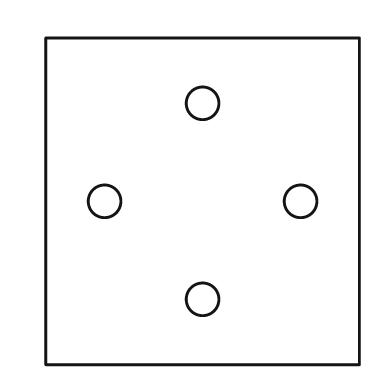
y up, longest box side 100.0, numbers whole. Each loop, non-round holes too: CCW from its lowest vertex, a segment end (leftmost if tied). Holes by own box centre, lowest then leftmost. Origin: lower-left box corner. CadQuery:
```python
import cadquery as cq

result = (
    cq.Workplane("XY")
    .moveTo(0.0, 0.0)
    .lineTo(96.0, 0.0)
    .lineTo(96.0, 100.0)
    .lineTo(0.0, 100.0)
    .close()
    .moveTo(48.0, 20.0)
    .circle(5.0)
    .moveTo(18.0, 50.0)
    .circle(5.0)
    .moveTo(78.0, 50.0)
    .circle(5.0)
    .moveTo(48.0, 80.0)
    .circle(5.0)
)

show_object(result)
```